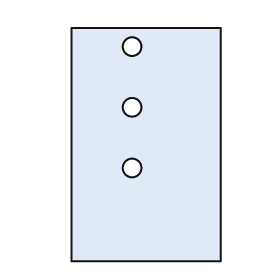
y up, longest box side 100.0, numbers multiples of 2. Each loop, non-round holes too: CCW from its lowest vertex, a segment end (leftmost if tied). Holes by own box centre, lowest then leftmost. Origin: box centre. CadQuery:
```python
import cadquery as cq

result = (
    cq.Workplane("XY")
    .moveTo(-32.0, -50.0)
    .lineTo(32.0, -50.0)
    .lineTo(32.0, 50.0)
    .lineTo(-32.0, 50.0)
    .close()
    .moveTo(-6.0, -10.0)
    .circle(4.0)
    .moveTo(-6.0, 16.0)
    .circle(4.0)
    .moveTo(-6.0, 42.0)
    .circle(4.0)
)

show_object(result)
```